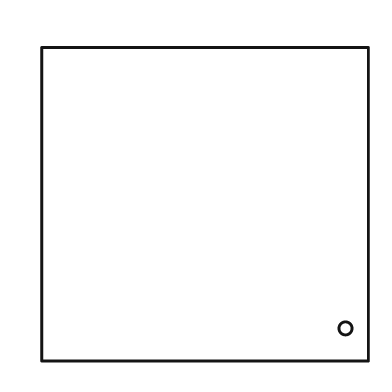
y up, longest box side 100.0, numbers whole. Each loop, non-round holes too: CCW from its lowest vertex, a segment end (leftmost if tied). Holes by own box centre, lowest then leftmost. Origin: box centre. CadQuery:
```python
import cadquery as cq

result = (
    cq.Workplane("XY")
    .moveTo(-50.0, -48.0)
    .lineTo(50.0, -48.0)
    .lineTo(50.0, 48.0)
    .lineTo(-50.0, 48.0)
    .close()
    .moveTo(43.0, -38.0)
    .circle(2.0)
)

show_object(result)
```